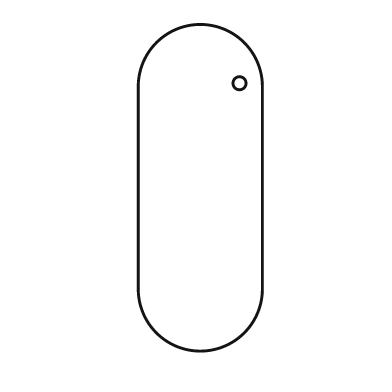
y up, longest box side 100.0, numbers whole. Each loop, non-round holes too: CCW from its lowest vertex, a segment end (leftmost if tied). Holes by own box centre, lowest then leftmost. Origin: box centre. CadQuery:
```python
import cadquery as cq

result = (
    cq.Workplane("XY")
    .moveTo(-19.0, -31.0)
    .threePointArc((0.0, -50.0), (19.0, -31.0))
    .lineTo(19.0, 31.0)
    .threePointArc((0.0, 50.0), (-19.0, 31.0))
    .close()
    .moveTo(12.0, 32.0)
    .circle(2.0)
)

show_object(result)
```